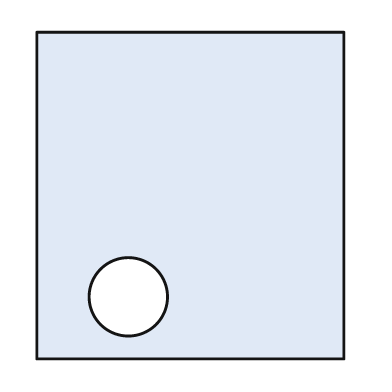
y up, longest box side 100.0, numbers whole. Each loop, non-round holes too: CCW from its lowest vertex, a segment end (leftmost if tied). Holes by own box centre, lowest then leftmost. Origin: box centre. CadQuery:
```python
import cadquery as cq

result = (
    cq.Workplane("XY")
    .moveTo(-47.0, -50.0)
    .lineTo(47.0, -50.0)
    .lineTo(47.0, 50.0)
    .lineTo(-47.0, 50.0)
    .close()
    .moveTo(-19.0, -31.0)
    .circle(12.0)
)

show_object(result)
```